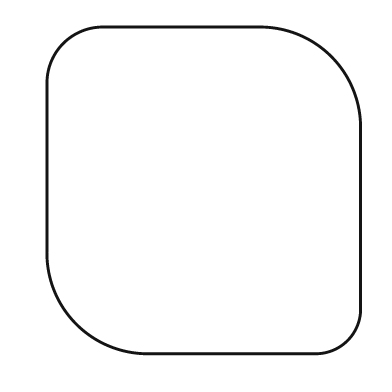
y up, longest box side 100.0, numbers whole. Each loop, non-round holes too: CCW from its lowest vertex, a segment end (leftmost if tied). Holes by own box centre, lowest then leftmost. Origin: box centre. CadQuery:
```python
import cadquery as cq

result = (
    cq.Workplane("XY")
    .moveTo(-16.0, -50.0)
    .lineTo(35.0, -50.0)
    .threePointArc((44.0, -46.0), (48.0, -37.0))
    .lineTo(48.0, 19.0)
    .threePointArc((39.0, 41.0), (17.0, 50.0))
    .lineTo(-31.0, 50.0)
    .threePointArc((-43.0, 45.0), (-48.0, 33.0))
    .lineTo(-48.0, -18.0)
    .threePointArc((-39.0, -41.0), (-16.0, -50.0))
    .close()
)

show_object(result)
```